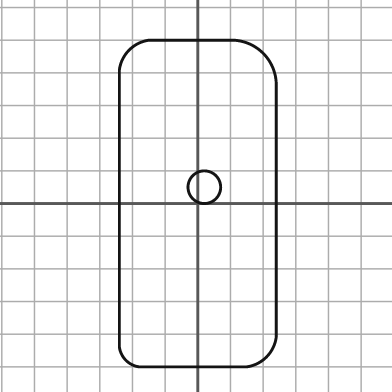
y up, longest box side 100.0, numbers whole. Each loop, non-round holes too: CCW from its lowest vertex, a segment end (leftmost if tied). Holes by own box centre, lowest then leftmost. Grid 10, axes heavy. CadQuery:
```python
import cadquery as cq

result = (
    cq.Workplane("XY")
    .moveTo(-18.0, -50.0)
    .lineTo(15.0, -50.0)
    .threePointArc((21.0, -47.0), (24.0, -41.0))
    .lineTo(24.0, 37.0)
    .threePointArc((20.0, 46.0), (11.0, 50.0))
    .lineTo(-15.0, 50.0)
    .threePointArc((-21.0, 47.0), (-24.0, 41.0))
    .lineTo(-24.0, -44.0)
    .threePointArc((-22.0, -48.0), (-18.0, -50.0))
    .close()
    .moveTo(2.0, 5.0)
    .circle(5.0)
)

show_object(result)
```